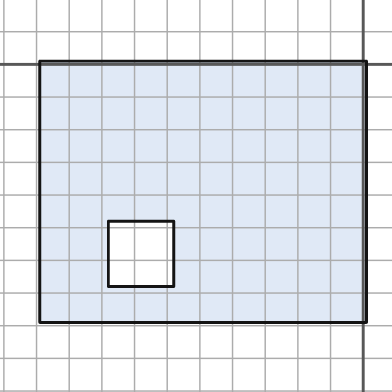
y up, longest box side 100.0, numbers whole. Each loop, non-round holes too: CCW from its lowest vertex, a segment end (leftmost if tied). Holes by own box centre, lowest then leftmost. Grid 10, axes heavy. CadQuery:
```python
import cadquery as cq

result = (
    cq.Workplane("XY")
    .moveTo(-99.0, -79.0)
    .lineTo(1.0, -79.0)
    .lineTo(1.0, 1.0)
    .lineTo(-99.0, 1.0)
    .close()
    .moveTo(-78.0, -68.0)
    .lineTo(-58.0, -68.0)
    .lineTo(-58.0, -48.0)
    .lineTo(-78.0, -48.0)
    .close()
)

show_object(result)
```